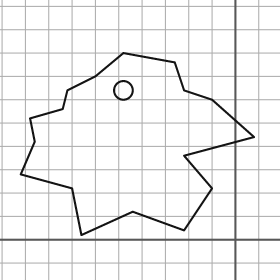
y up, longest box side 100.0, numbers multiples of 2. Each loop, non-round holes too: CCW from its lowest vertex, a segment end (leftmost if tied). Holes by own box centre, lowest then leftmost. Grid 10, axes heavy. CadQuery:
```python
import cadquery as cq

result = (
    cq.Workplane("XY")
    .moveTo(-66.0, 2.0)
    .lineTo(-44.0, 12.0)
    .lineTo(-22.0, 4.0)
    .lineTo(-10.0, 22.0)
    .lineTo(-22.0, 36.0)
    .lineTo(8.0, 44.0)
    .lineTo(-10.0, 60.0)
    .lineTo(-22.0, 64.0)
    .lineTo(-26.0, 76.0)
    .lineTo(-48.0, 80.0)
    .lineTo(-60.0, 70.0)
    .lineTo(-72.0, 64.0)
    .lineTo(-74.0, 56.0)
    .lineTo(-88.0, 52.0)
    .lineTo(-86.0, 42.0)
    .lineTo(-92.0, 28.0)
    .lineTo(-70.0, 22.0)
    .close()
    .moveTo(-48.0, 64.0)
    .circle(4.0)
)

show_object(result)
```